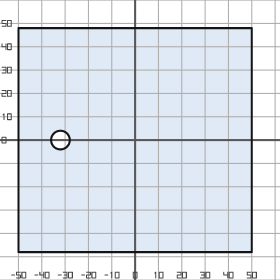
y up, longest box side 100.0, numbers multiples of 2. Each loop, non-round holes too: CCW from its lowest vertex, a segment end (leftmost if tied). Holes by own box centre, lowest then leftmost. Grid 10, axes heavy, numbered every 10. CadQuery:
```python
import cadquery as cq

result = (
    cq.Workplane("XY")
    .moveTo(-50.0, -48.0)
    .lineTo(50.0, -48.0)
    .lineTo(50.0, 48.0)
    .lineTo(-50.0, 48.0)
    .close()
    .moveTo(-32.0, 0.0)
    .circle(4.0)
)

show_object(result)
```